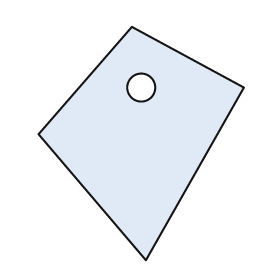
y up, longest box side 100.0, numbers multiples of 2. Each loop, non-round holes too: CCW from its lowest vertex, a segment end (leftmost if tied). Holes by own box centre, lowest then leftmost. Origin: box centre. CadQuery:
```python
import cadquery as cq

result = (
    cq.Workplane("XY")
    .moveTo(2.0, -50.0)
    .lineTo(44.0, 24.0)
    .lineTo(-4.0, 50.0)
    .lineTo(-44.0, 4.0)
    .close()
    .moveTo(0.0, 24.0)
    .circle(6.0)
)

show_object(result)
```